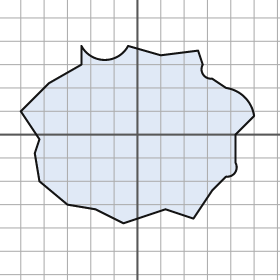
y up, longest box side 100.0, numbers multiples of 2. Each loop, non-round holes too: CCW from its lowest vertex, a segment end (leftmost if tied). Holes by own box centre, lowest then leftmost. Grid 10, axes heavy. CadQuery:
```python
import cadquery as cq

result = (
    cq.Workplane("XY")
    .moveTo(-6.0, -38.0)
    .lineTo(12.0, -32.0)
    .lineTo(24.0, -36.0)
    .lineTo(32.0, -24.0)
    .lineTo(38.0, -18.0)
    .threePointArc((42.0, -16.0), (42.0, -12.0))
    .lineTo(42.0, 0.0)
    .lineTo(50.0, 8.0)
    .threePointArc((46.0, 16.0), (38.0, 20.0))
    .lineTo(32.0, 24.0)
    .threePointArc((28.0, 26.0), (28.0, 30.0))
    .lineTo(26.0, 36.0)
    .lineTo(10.0, 34.0)
    .lineTo(-4.0, 38.0)
    .threePointArc((-14.0, 32.0), (-24.0, 38.0))
    .lineTo(-24.0, 30.0)
    .lineTo(-38.0, 22.0)
    .lineTo(-50.0, 10.0)
    .lineTo(-42.0, -2.0)
    .lineTo(-44.0, -8.0)
    .lineTo(-42.0, -20.0)
    .lineTo(-30.0, -30.0)
    .lineTo(-18.0, -32.0)
    .close()
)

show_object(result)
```